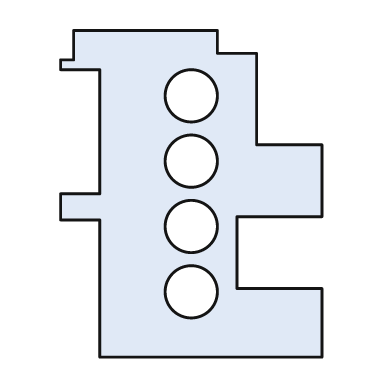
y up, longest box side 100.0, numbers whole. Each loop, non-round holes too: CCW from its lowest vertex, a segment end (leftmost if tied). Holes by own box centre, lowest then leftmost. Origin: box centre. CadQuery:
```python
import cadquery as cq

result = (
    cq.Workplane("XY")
    .moveTo(-28.0, -50.0)
    .lineTo(40.0, -50.0)
    .lineTo(40.0, -29.0)
    .lineTo(14.0, -29.0)
    .lineTo(14.0, -7.0)
    .lineTo(40.0, -7.0)
    .lineTo(40.0, 15.0)
    .lineTo(20.0, 15.0)
    .lineTo(20.0, 43.0)
    .lineTo(8.0, 43.0)
    .lineTo(8.0, 50.0)
    .lineTo(-36.0, 50.0)
    .lineTo(-36.0, 41.0)
    .lineTo(-40.0, 41.0)
    .lineTo(-40.0, 38.0)
    .lineTo(-28.0, 38.0)
    .lineTo(-28.0, 0.0)
    .lineTo(-40.0, 0.0)
    .lineTo(-40.0, -8.0)
    .lineTo(-28.0, -8.0)
    .close()
    .moveTo(0.0, -30.0)
    .circle(8.0)
    .moveTo(0.0, -10.0)
    .circle(8.0)
    .moveTo(0.0, 10.0)
    .circle(8.0)
    .moveTo(0.0, 30.0)
    .circle(8.0)
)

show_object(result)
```